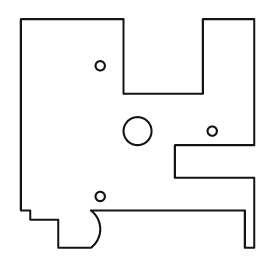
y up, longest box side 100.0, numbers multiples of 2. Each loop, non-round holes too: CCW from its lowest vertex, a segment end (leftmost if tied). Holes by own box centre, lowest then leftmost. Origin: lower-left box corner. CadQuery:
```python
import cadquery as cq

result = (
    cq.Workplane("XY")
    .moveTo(16.0, 0.0)
    .lineTo(30.0, 0.0)
    .threePointArc((34.0, 8.0), (30.0, 16.0))
    .lineTo(96.0, 16.0)
    .lineTo(96.0, 0.0)
    .lineTo(100.0, 0.0)
    .lineTo(100.0, 30.0)
    .lineTo(66.0, 30.0)
    .lineTo(66.0, 44.0)
    .lineTo(100.0, 44.0)
    .lineTo(100.0, 98.0)
    .lineTo(78.0, 98.0)
    .lineTo(78.0, 66.0)
    .lineTo(44.0, 66.0)
    .lineTo(44.0, 98.0)
    .lineTo(0.0, 98.0)
    .lineTo(0.0, 16.0)
    .lineTo(4.0, 16.0)
    .lineTo(4.0, 12.0)
    .lineTo(16.0, 12.0)
    .close()
    .moveTo(34.0, 22.0)
    .circle(2.0)
    .moveTo(50.0, 50.0)
    .circle(6.0)
    .moveTo(82.0, 50.0)
    .circle(2.0)
    .moveTo(34.0, 78.0)
    .circle(2.0)
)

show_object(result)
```